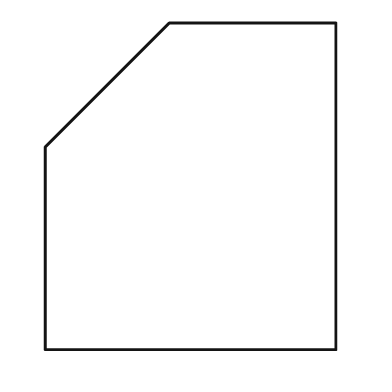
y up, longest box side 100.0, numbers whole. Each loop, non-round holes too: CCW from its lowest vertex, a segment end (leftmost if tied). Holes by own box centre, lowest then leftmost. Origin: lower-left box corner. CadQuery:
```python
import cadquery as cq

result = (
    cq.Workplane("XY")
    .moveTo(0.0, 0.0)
    .lineTo(89.0, 0.0)
    .lineTo(89.0, 100.0)
    .lineTo(38.0, 100.0)
    .lineTo(0.0, 62.0)
    .close()
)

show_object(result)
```